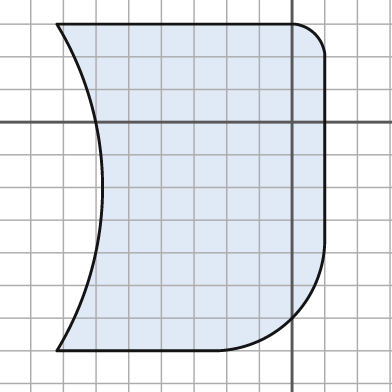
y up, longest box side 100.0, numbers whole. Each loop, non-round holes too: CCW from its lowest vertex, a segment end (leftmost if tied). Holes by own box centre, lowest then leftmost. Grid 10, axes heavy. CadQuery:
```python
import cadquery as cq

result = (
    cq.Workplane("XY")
    .moveTo(-72.0, -70.0)
    .lineTo(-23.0, -70.0)
    .threePointArc((0.0, -60.0), (10.0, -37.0))
    .lineTo(10.0, 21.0)
    .threePointArc((7.0, 27.0), (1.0, 30.0))
    .lineTo(-72.0, 30.0)
    .threePointArc((-58.0, -20.0), (-72.0, -70.0))
    .close()
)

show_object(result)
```